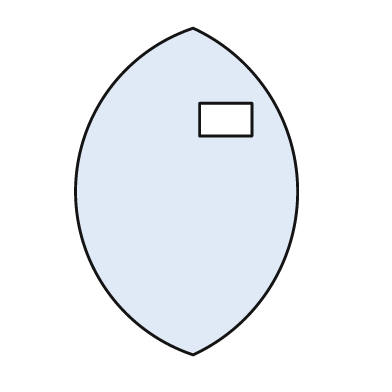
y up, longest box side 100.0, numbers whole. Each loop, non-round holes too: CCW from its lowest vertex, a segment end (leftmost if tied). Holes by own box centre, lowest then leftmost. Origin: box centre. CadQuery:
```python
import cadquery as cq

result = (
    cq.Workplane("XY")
    .moveTo(2.0, -50.0)
    .threePointArc((34.0, 0.0), (2.0, 50.0))
    .threePointArc((-34.0, 0.0), (2.0, -50.0))
    .close()
    .moveTo(4.0, 17.0)
    .lineTo(20.0, 17.0)
    .lineTo(20.0, 27.0)
    .lineTo(4.0, 27.0)
    .close()
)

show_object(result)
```